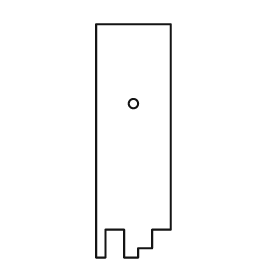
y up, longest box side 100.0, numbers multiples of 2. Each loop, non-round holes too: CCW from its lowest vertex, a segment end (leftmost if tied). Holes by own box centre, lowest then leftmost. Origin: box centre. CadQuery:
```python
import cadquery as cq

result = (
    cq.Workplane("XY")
    .moveTo(-16.0, -50.0)
    .lineTo(-12.0, -50.0)
    .lineTo(-12.0, -38.0)
    .lineTo(-4.0, -38.0)
    .lineTo(-4.0, -50.0)
    .lineTo(2.0, -50.0)
    .lineTo(2.0, -46.0)
    .lineTo(8.0, -46.0)
    .lineTo(8.0, -38.0)
    .lineTo(16.0, -38.0)
    .lineTo(16.0, 50.0)
    .lineTo(-16.0, 50.0)
    .close()
    .moveTo(0.0, 16.0)
    .circle(2.0)
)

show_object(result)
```